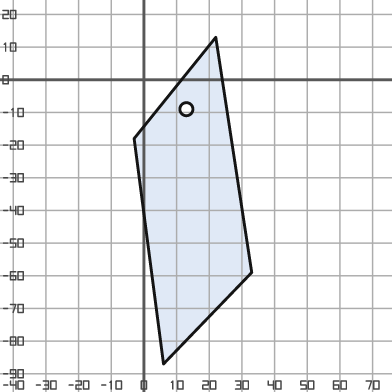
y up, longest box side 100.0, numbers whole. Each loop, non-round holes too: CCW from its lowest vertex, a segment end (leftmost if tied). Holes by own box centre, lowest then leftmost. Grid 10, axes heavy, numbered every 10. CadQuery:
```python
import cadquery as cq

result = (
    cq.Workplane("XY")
    .moveTo(6.0, -87.0)
    .lineTo(33.0, -59.0)
    .lineTo(22.0, 13.0)
    .lineTo(-3.0, -18.0)
    .close()
    .moveTo(13.0, -9.0)
    .circle(2.0)
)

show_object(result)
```